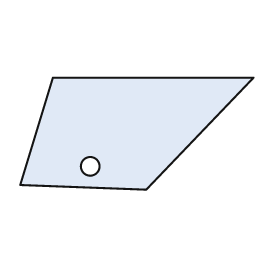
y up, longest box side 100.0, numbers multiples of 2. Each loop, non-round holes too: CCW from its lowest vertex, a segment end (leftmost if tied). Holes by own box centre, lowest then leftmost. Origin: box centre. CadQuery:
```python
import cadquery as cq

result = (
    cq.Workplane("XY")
    .moveTo(4.0, -24.0)
    .lineTo(50.0, 24.0)
    .lineTo(-36.0, 24.0)
    .lineTo(-50.0, -22.0)
    .close()
    .moveTo(-20.0, -14.0)
    .circle(4.0)
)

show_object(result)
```